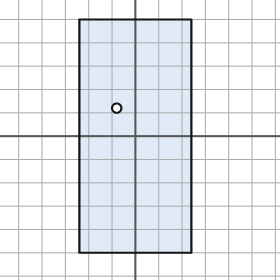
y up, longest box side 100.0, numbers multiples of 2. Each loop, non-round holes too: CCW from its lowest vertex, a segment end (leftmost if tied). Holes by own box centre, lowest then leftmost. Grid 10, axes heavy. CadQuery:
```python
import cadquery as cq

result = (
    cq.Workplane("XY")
    .moveTo(-24.0, -50.0)
    .lineTo(24.0, -50.0)
    .lineTo(24.0, 50.0)
    .lineTo(-24.0, 50.0)
    .close()
    .moveTo(-8.0, 12.0)
    .circle(2.0)
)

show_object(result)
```